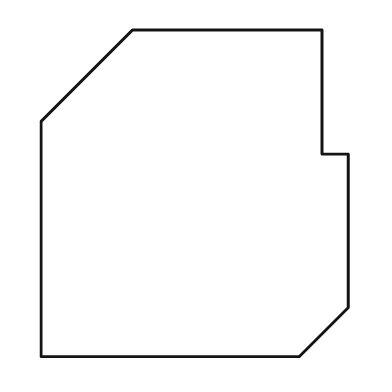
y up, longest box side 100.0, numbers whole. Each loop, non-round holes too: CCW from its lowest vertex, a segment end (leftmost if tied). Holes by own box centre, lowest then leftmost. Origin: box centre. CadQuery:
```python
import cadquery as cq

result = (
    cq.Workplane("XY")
    .moveTo(-47.0, -50.0)
    .lineTo(32.0, -50.0)
    .lineTo(47.0, -35.0)
    .lineTo(47.0, 12.0)
    .lineTo(39.0, 12.0)
    .lineTo(39.0, 50.0)
    .lineTo(-19.0, 50.0)
    .lineTo(-47.0, 22.0)
    .close()
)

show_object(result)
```